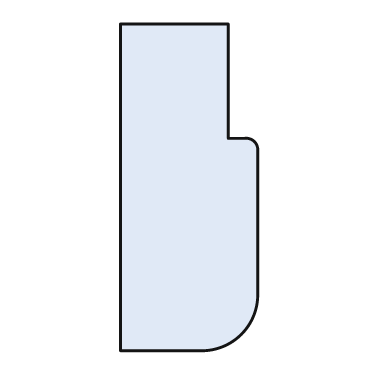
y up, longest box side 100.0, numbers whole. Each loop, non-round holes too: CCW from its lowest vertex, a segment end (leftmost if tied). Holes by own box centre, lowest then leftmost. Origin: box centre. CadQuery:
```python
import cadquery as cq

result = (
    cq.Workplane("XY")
    .moveTo(-21.0, -50.0)
    .lineTo(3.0, -50.0)
    .threePointArc((16.0, -45.0), (21.0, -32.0))
    .lineTo(21.0, 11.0)
    .threePointArc((20.0, 14.0), (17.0, 15.0))
    .lineTo(12.0, 15.0)
    .lineTo(12.0, 50.0)
    .lineTo(-21.0, 50.0)
    .close()
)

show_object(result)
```